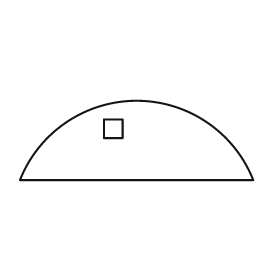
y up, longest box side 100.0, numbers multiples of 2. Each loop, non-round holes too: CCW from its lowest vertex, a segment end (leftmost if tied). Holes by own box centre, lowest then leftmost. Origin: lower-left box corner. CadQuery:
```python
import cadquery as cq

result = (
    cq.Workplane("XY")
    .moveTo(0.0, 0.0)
    .lineTo(100.0, 0.0)
    .threePointArc((50.0, 34.0), (0.0, 0.0))
    .close()
    .moveTo(36.0, 18.0)
    .lineTo(44.0, 18.0)
    .lineTo(44.0, 26.0)
    .lineTo(36.0, 26.0)
    .close()
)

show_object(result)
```